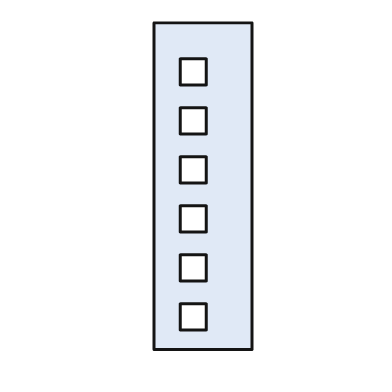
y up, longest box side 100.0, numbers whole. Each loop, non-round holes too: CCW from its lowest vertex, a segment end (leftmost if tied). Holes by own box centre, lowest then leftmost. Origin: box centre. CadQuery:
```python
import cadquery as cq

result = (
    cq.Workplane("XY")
    .moveTo(-15.0, -50.0)
    .lineTo(15.0, -50.0)
    .lineTo(15.0, 50.0)
    .lineTo(-15.0, 50.0)
    .close()
    .moveTo(-7.0, -44.0)
    .lineTo(1.0, -44.0)
    .lineTo(1.0, -36.0)
    .lineTo(-7.0, -36.0)
    .close()
    .moveTo(-7.0, -29.0)
    .lineTo(1.0, -29.0)
    .lineTo(1.0, -21.0)
    .lineTo(-7.0, -21.0)
    .close()
    .moveTo(-7.0, -14.0)
    .lineTo(1.0, -14.0)
    .lineTo(1.0, -6.0)
    .lineTo(-7.0, -6.0)
    .close()
    .moveTo(-7.0, 1.0)
    .lineTo(1.0, 1.0)
    .lineTo(1.0, 9.0)
    .lineTo(-7.0, 9.0)
    .close()
    .moveTo(-7.0, 16.0)
    .lineTo(1.0, 16.0)
    .lineTo(1.0, 24.0)
    .lineTo(-7.0, 24.0)
    .close()
    .moveTo(-7.0, 31.0)
    .lineTo(1.0, 31.0)
    .lineTo(1.0, 39.0)
    .lineTo(-7.0, 39.0)
    .close()
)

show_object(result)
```